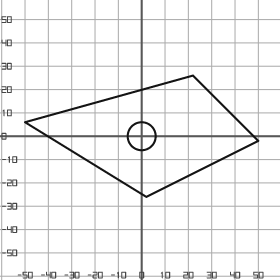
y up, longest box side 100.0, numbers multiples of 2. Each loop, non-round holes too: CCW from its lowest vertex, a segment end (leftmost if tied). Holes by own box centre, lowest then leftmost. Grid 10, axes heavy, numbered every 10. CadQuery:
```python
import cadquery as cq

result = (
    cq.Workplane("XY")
    .moveTo(2.0, -26.0)
    .lineTo(50.0, -2.0)
    .lineTo(22.0, 26.0)
    .lineTo(-50.0, 6.0)
    .close()
    .moveTo(0.0, 0.0)
    .circle(6.0)
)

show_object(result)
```